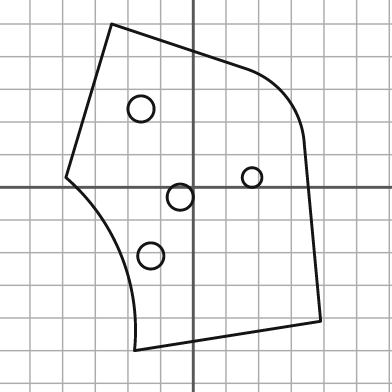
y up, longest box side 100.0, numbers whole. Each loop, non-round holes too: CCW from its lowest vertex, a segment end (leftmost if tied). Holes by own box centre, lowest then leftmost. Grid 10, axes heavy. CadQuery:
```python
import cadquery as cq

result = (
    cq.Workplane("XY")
    .moveTo(-18.0, -50.0)
    .lineTo(39.0, -41.0)
    .lineTo(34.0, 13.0)
    .threePointArc((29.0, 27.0), (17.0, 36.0))
    .lineTo(-25.0, 50.0)
    .lineTo(-39.0, 3.0)
    .threePointArc((-22.0, -21.0), (-18.0, -50.0))
    .close()
    .moveTo(-13.0, -21.0)
    .circle(4.0)
    .moveTo(-4.0, -3.0)
    .circle(4.0)
    .moveTo(18.0, 3.0)
    .circle(3.0)
    .moveTo(-16.0, 24.0)
    .circle(4.0)
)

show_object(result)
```